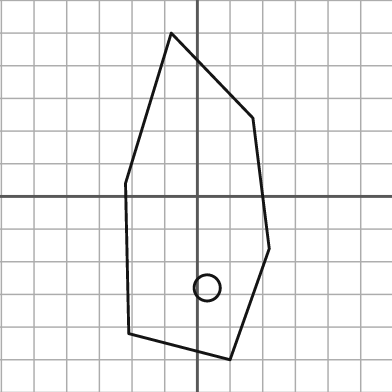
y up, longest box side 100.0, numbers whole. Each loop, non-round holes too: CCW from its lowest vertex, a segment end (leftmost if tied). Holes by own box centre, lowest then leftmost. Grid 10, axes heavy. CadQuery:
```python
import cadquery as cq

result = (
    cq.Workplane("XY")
    .moveTo(10.0, -50.0)
    .lineTo(22.0, -16.0)
    .lineTo(17.0, 24.0)
    .lineTo(-8.0, 50.0)
    .lineTo(-22.0, 4.0)
    .lineTo(-21.0, -42.0)
    .close()
    .moveTo(3.0, -28.0)
    .circle(4.0)
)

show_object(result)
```